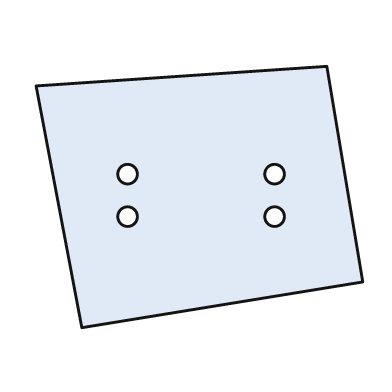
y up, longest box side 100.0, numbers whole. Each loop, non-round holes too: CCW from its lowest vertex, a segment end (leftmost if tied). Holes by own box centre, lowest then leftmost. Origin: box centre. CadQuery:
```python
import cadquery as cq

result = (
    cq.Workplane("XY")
    .moveTo(-36.0, -40.0)
    .lineTo(50.0, -26.0)
    .lineTo(39.0, 40.0)
    .lineTo(-50.0, 34.0)
    .close()
    .moveTo(-22.0, -6.0)
    .circle(3.0)
    .moveTo(23.0, -6.0)
    .circle(3.0)
    .moveTo(-22.0, 7.0)
    .circle(3.0)
    .moveTo(23.0, 7.0)
    .circle(3.0)
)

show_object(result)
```